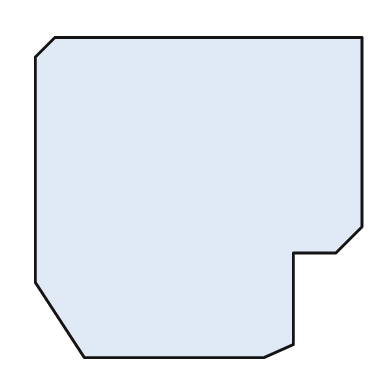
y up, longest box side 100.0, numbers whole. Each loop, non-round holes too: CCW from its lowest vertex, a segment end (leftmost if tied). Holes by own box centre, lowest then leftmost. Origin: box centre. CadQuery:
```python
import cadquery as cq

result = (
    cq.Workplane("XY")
    .moveTo(-35.0, -49.0)
    .lineTo(20.0, -49.0)
    .lineTo(29.0, -45.0)
    .lineTo(29.0, -17.0)
    .lineTo(42.0, -17.0)
    .lineTo(50.0, -9.0)
    .lineTo(50.0, 49.0)
    .lineTo(-44.0, 49.0)
    .lineTo(-50.0, 43.0)
    .lineTo(-50.0, -26.0)
    .close()
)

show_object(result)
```